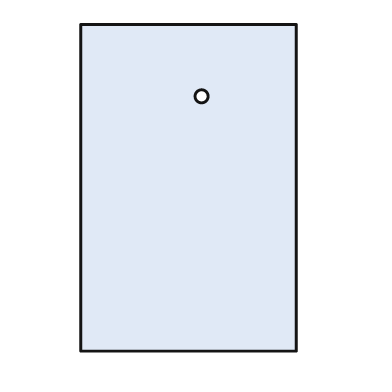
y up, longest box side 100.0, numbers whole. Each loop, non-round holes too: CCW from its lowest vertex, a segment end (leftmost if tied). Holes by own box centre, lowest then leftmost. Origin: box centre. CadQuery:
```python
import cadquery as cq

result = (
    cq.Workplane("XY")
    .moveTo(-33.0, -50.0)
    .lineTo(33.0, -50.0)
    .lineTo(33.0, 50.0)
    .lineTo(-33.0, 50.0)
    .close()
    .moveTo(4.0, 28.0)
    .circle(2.0)
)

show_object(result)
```